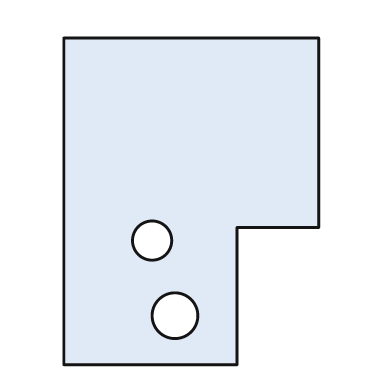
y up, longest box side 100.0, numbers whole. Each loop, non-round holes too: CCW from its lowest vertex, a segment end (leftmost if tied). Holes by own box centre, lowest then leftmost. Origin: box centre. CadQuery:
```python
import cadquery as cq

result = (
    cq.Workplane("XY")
    .moveTo(-39.0, -50.0)
    .lineTo(14.0, -50.0)
    .lineTo(14.0, -8.0)
    .lineTo(39.0, -8.0)
    .lineTo(39.0, 50.0)
    .lineTo(-39.0, 50.0)
    .close()
    .moveTo(-5.0, -35.0)
    .circle(7.0)
    .moveTo(-12.0, -12.0)
    .circle(6.0)
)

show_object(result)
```